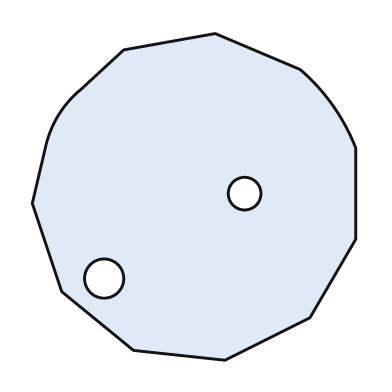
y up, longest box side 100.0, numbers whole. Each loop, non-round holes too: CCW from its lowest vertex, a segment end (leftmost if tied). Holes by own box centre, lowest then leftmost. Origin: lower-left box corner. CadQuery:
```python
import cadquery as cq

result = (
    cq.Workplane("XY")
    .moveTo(59.0, 0.0)
    .lineTo(85.0, 13.0)
    .lineTo(99.0, 37.0)
    .lineTo(99.0, 65.0)
    .threePointArc((92.0, 78.0), (82.0, 89.0))
    .lineTo(56.0, 100.0)
    .lineTo(28.0, 95.0)
    .lineTo(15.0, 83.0)
    .threePointArc((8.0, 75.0), (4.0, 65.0))
    .lineTo(0.0, 48.0)
    .lineTo(9.0, 21.0)
    .lineTo(31.0, 3.0)
    .close()
    .moveTo(22.0, 25.0)
    .circle(6.0)
    .moveTo(65.0, 51.0)
    .circle(5.0)
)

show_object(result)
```